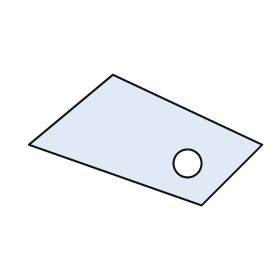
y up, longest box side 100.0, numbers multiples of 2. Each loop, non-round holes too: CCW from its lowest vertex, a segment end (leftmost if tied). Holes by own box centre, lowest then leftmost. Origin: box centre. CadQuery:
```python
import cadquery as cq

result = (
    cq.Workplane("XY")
    .moveTo(24.0, -28.0)
    .lineTo(50.0, -2.0)
    .lineTo(-14.0, 28.0)
    .lineTo(-50.0, -2.0)
    .close()
    .moveTo(18.0, -10.0)
    .circle(6.0)
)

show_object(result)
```